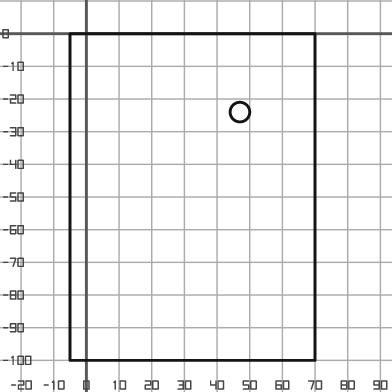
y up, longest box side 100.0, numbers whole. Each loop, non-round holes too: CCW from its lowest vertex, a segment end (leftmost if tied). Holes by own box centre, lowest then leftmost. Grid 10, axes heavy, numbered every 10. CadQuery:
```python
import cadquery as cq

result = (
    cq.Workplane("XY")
    .moveTo(-5.0, -100.0)
    .lineTo(70.0, -100.0)
    .lineTo(70.0, 0.0)
    .lineTo(-5.0, 0.0)
    .close()
    .moveTo(47.0, -24.0)
    .circle(3.0)
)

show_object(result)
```